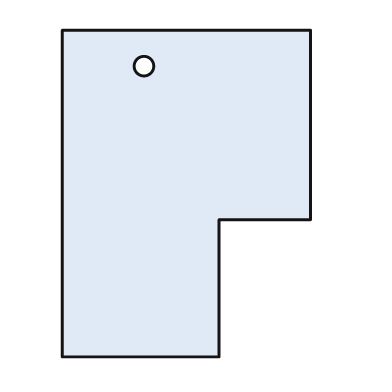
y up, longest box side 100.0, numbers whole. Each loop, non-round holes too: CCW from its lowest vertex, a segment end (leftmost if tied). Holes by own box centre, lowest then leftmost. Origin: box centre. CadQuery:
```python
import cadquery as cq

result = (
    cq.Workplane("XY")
    .moveTo(-38.0, -50.0)
    .lineTo(10.0, -50.0)
    .lineTo(10.0, -8.0)
    .lineTo(38.0, -8.0)
    .lineTo(38.0, 50.0)
    .lineTo(-38.0, 50.0)
    .close()
    .moveTo(-13.0, 39.0)
    .circle(3.0)
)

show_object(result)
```